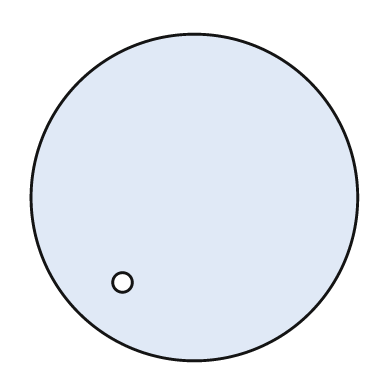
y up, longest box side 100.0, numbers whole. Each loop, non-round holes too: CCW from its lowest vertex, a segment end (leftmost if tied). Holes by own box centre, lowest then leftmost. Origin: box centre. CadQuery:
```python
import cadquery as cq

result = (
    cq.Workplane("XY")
    .moveTo(0.0, 0.0)
    .circle(50.0)
    .moveTo(-22.0, -26.0)
    .circle(3.0)
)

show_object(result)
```